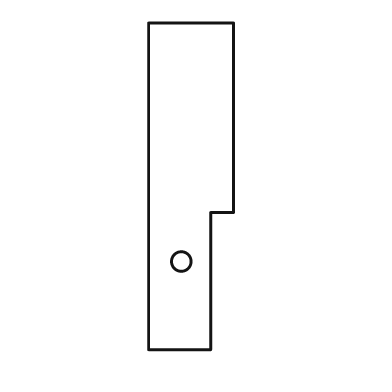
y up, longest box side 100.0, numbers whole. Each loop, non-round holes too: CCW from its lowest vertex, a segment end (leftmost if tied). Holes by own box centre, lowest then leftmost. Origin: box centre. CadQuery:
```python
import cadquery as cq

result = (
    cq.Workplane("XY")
    .moveTo(-13.0, -50.0)
    .lineTo(6.0, -50.0)
    .lineTo(6.0, -8.0)
    .lineTo(13.0, -8.0)
    .lineTo(13.0, 50.0)
    .lineTo(-13.0, 50.0)
    .close()
    .moveTo(-3.0, -23.0)
    .circle(3.0)
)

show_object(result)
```